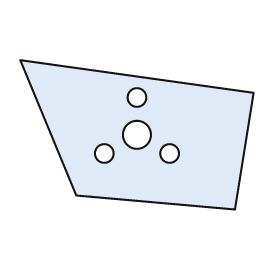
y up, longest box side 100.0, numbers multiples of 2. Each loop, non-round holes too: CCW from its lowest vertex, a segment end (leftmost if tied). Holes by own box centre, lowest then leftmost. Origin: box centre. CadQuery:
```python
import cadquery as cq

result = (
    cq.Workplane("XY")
    .moveTo(42.0, -32.0)
    .lineTo(50.0, 18.0)
    .lineTo(-50.0, 32.0)
    .lineTo(-26.0, -26.0)
    .close()
    .moveTo(-14.0, -8.0)
    .circle(4.0)
    .moveTo(14.0, -8.0)
    .circle(4.0)
    .moveTo(0.0, 0.0)
    .circle(6.0)
    .moveTo(0.0, 16.0)
    .circle(4.0)
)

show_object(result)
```